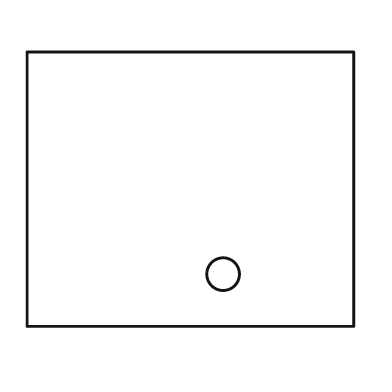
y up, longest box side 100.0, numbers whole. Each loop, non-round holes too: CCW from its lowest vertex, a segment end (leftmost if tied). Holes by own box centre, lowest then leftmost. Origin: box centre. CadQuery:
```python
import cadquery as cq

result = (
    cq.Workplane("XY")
    .moveTo(-50.0, -42.0)
    .lineTo(50.0, -42.0)
    .lineTo(50.0, 42.0)
    .lineTo(-50.0, 42.0)
    .close()
    .moveTo(10.0, -26.0)
    .circle(5.0)
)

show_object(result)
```